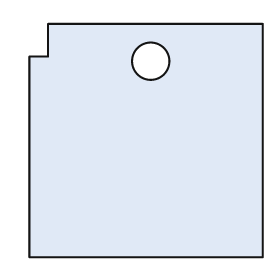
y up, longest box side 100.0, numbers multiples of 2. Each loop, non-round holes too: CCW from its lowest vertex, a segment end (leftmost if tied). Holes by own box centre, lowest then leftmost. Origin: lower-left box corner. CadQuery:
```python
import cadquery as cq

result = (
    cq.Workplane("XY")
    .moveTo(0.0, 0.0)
    .lineTo(100.0, 0.0)
    .lineTo(100.0, 100.0)
    .lineTo(8.0, 100.0)
    .lineTo(8.0, 86.0)
    .lineTo(0.0, 86.0)
    .close()
    .moveTo(52.0, 84.0)
    .circle(8.0)
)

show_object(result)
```